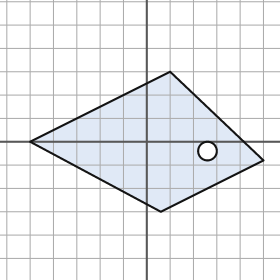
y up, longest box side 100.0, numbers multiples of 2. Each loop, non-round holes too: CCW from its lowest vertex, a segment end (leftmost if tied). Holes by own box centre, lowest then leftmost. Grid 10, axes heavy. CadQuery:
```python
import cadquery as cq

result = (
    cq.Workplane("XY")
    .moveTo(6.0, -30.0)
    .lineTo(50.0, -8.0)
    .lineTo(10.0, 30.0)
    .lineTo(-50.0, 0.0)
    .close()
    .moveTo(26.0, -4.0)
    .circle(4.0)
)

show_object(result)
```